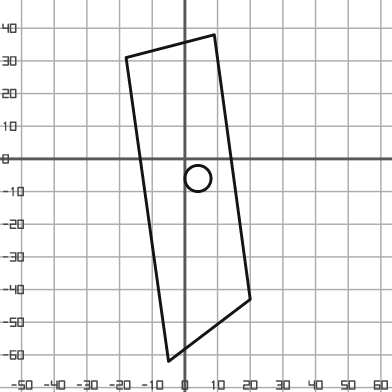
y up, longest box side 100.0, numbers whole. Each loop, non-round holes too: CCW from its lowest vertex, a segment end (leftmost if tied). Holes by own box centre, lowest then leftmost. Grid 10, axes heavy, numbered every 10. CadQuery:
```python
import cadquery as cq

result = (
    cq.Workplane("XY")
    .moveTo(-5.0, -62.0)
    .lineTo(20.0, -43.0)
    .lineTo(9.0, 38.0)
    .lineTo(-18.0, 31.0)
    .close()
    .moveTo(4.0, -6.0)
    .circle(4.0)
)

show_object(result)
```